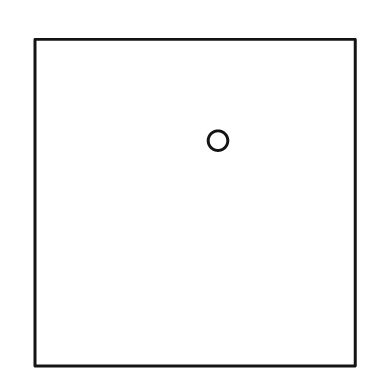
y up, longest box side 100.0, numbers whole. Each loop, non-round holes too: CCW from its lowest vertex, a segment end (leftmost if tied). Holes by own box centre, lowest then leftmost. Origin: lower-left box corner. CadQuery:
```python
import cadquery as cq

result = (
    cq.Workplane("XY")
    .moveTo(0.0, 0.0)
    .lineTo(98.0, 0.0)
    .lineTo(98.0, 100.0)
    .lineTo(0.0, 100.0)
    .close()
    .moveTo(56.0, 69.0)
    .circle(3.0)
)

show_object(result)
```